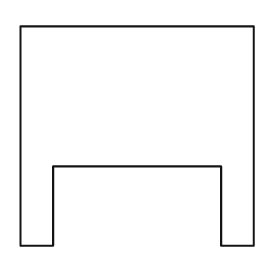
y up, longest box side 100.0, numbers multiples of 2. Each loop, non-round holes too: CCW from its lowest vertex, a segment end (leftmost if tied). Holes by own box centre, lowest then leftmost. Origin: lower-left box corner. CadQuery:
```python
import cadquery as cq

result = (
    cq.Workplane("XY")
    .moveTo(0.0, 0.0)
    .lineTo(14.0, 0.0)
    .lineTo(14.0, 34.0)
    .lineTo(86.0, 34.0)
    .lineTo(86.0, 0.0)
    .lineTo(100.0, 0.0)
    .lineTo(100.0, 94.0)
    .lineTo(0.0, 94.0)
    .close()
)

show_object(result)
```